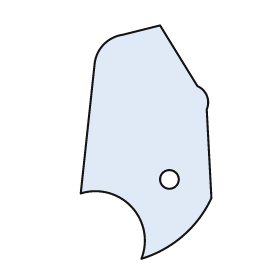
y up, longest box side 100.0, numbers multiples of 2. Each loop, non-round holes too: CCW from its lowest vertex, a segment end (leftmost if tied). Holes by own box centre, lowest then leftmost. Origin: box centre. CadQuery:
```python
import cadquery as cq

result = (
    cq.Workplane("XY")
    .moveTo(-2.0, -50.0)
    .threePointArc((16.0, -40.0), (28.0, -24.0))
    .lineTo(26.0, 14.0)
    .threePointArc((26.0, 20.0), (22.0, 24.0))
    .lineTo(6.0, 50.0)
    .lineTo(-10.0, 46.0)
    .threePointArc((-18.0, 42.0), (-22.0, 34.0))
    .lineTo(-28.0, -22.0)
    .threePointArc((-6.0, -28.0), (-2.0, -50.0))
    .close()
    .moveTo(10.0, -16.0)
    .circle(4.0)
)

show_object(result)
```